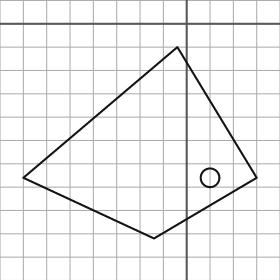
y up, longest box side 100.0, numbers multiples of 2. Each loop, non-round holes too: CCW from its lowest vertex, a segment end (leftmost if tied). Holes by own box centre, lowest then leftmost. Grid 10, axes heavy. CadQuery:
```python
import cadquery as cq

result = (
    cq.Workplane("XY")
    .moveTo(-14.0, -92.0)
    .lineTo(30.0, -66.0)
    .lineTo(-4.0, -10.0)
    .lineTo(-70.0, -66.0)
    .close()
    .moveTo(10.0, -66.0)
    .circle(4.0)
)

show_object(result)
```